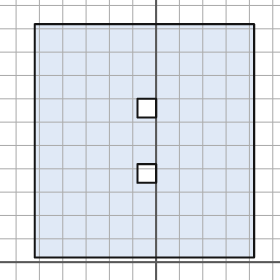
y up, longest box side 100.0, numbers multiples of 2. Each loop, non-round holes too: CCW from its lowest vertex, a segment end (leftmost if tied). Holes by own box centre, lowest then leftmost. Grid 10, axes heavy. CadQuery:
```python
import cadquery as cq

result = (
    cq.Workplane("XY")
    .moveTo(-52.0, 2.0)
    .lineTo(42.0, 2.0)
    .lineTo(42.0, 102.0)
    .lineTo(-52.0, 102.0)
    .close()
    .moveTo(-8.0, 34.0)
    .lineTo(0.0, 34.0)
    .lineTo(0.0, 42.0)
    .lineTo(-8.0, 42.0)
    .close()
    .moveTo(-8.0, 62.0)
    .lineTo(0.0, 62.0)
    .lineTo(0.0, 70.0)
    .lineTo(-8.0, 70.0)
    .close()
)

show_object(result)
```